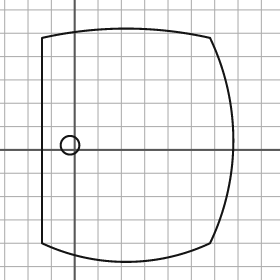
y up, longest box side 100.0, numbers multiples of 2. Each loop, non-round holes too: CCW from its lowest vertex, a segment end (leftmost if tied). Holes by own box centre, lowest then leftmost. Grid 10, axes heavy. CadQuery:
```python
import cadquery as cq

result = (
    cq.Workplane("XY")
    .moveTo(-14.0, -40.0)
    .threePointArc((22.0, -48.0), (58.0, -40.0))
    .threePointArc((68.0, 4.0), (58.0, 48.0))
    .threePointArc((22.0, 52.0), (-14.0, 48.0))
    .close()
    .moveTo(-2.0, 2.0)
    .circle(4.0)
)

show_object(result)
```